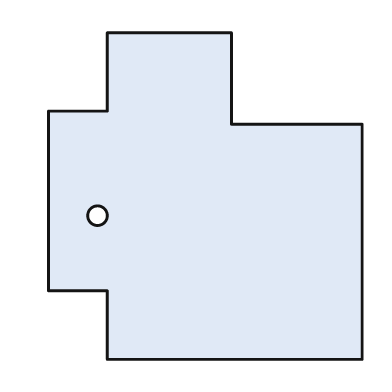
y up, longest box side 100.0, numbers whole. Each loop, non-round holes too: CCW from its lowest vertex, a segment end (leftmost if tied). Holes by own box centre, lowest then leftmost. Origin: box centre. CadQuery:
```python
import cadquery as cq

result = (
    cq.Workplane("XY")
    .moveTo(-30.0, -50.0)
    .lineTo(48.0, -50.0)
    .lineTo(48.0, 22.0)
    .lineTo(8.0, 22.0)
    .lineTo(8.0, 50.0)
    .lineTo(-30.0, 50.0)
    .lineTo(-30.0, 26.0)
    .lineTo(-48.0, 26.0)
    .lineTo(-48.0, -29.0)
    .lineTo(-30.0, -29.0)
    .close()
    .moveTo(-33.0, -6.0)
    .circle(3.0)
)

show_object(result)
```